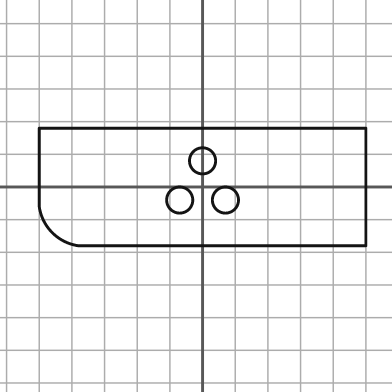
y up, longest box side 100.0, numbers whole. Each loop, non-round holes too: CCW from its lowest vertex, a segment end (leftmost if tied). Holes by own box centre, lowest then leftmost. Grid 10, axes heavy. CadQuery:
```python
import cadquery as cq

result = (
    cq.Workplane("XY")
    .moveTo(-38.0, -18.0)
    .lineTo(50.0, -18.0)
    .lineTo(50.0, 18.0)
    .lineTo(-50.0, 18.0)
    .lineTo(-50.0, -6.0)
    .threePointArc((-46.0, -14.0), (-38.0, -18.0))
    .close()
    .moveTo(-7.0, -4.0)
    .circle(4.0)
    .moveTo(7.0, -4.0)
    .circle(4.0)
    .moveTo(0.0, 8.0)
    .circle(4.0)
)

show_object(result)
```